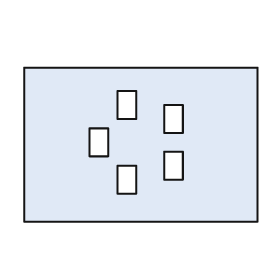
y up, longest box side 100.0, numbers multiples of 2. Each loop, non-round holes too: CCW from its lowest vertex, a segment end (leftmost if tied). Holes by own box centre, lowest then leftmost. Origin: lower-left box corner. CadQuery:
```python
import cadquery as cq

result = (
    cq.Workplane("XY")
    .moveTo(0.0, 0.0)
    .lineTo(100.0, 0.0)
    .lineTo(100.0, 66.0)
    .lineTo(0.0, 66.0)
    .close()
    .moveTo(40.0, 12.0)
    .lineTo(48.0, 12.0)
    .lineTo(48.0, 24.0)
    .lineTo(40.0, 24.0)
    .close()
    .moveTo(60.0, 18.0)
    .lineTo(68.0, 18.0)
    .lineTo(68.0, 30.0)
    .lineTo(60.0, 30.0)
    .close()
    .moveTo(28.0, 28.0)
    .lineTo(36.0, 28.0)
    .lineTo(36.0, 40.0)
    .lineTo(28.0, 40.0)
    .close()
    .moveTo(60.0, 38.0)
    .lineTo(68.0, 38.0)
    .lineTo(68.0, 50.0)
    .lineTo(60.0, 50.0)
    .close()
    .moveTo(40.0, 44.0)
    .lineTo(48.0, 44.0)
    .lineTo(48.0, 56.0)
    .lineTo(40.0, 56.0)
    .close()
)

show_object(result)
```